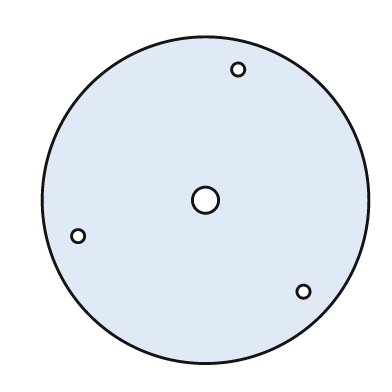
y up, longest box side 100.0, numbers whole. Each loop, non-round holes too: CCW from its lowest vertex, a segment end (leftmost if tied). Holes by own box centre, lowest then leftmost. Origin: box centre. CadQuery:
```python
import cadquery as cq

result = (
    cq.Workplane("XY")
    .moveTo(0.0, 0.0)
    .circle(50.0)
    .moveTo(30.0, -28.0)
    .circle(2.0)
    .moveTo(-39.0, -11.0)
    .circle(2.0)
    .moveTo(0.0, 0.0)
    .circle(4.0)
    .moveTo(10.0, 40.0)
    .circle(2.0)
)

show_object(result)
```